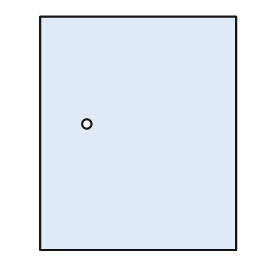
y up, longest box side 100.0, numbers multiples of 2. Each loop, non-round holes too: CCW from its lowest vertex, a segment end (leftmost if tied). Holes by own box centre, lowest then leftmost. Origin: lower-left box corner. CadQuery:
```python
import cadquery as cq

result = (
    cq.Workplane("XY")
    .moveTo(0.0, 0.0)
    .lineTo(84.0, 0.0)
    .lineTo(84.0, 100.0)
    .lineTo(0.0, 100.0)
    .close()
    .moveTo(20.0, 54.0)
    .circle(2.0)
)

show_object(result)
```